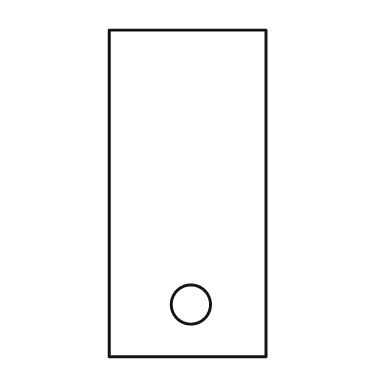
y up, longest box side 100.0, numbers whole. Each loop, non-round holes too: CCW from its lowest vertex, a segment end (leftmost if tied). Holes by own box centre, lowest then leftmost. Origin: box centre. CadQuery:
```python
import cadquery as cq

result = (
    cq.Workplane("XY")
    .moveTo(-24.0, -50.0)
    .lineTo(24.0, -50.0)
    .lineTo(24.0, 50.0)
    .lineTo(-24.0, 50.0)
    .close()
    .moveTo(1.0, -34.0)
    .circle(6.0)
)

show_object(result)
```